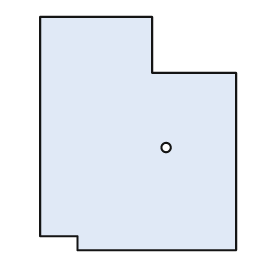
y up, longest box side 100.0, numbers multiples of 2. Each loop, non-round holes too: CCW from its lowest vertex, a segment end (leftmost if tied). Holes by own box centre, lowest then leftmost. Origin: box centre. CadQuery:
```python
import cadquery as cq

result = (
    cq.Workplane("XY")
    .moveTo(-26.0, -50.0)
    .lineTo(42.0, -50.0)
    .lineTo(42.0, 26.0)
    .lineTo(6.0, 26.0)
    .lineTo(6.0, 50.0)
    .lineTo(-42.0, 50.0)
    .lineTo(-42.0, -44.0)
    .lineTo(-26.0, -44.0)
    .close()
    .moveTo(12.0, -6.0)
    .circle(2.0)
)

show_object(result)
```